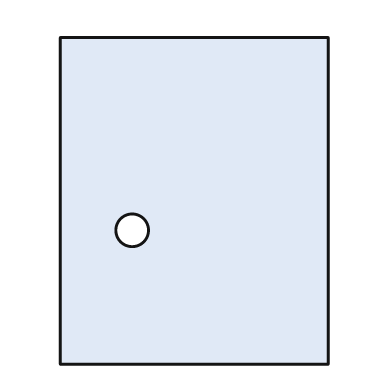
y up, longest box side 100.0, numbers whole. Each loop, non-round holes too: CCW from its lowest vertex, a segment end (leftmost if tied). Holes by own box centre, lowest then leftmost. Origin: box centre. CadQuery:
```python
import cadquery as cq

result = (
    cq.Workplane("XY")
    .moveTo(-41.0, -50.0)
    .lineTo(41.0, -50.0)
    .lineTo(41.0, 50.0)
    .lineTo(-41.0, 50.0)
    .close()
    .moveTo(-19.0, -9.0)
    .circle(5.0)
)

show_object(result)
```